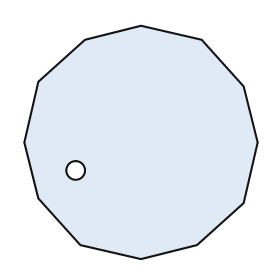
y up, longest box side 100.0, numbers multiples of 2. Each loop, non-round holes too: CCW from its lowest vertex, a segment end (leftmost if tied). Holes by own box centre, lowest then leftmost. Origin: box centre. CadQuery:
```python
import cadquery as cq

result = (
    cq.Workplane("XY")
    .moveTo(0.0, -50.0)
    .lineTo(24.0, -44.0)
    .lineTo(44.0, -26.0)
    .lineTo(50.0, 0.0)
    .lineTo(44.0, 24.0)
    .lineTo(26.0, 44.0)
    .lineTo(0.0, 50.0)
    .lineTo(-24.0, 44.0)
    .lineTo(-44.0, 26.0)
    .lineTo(-50.0, 0.0)
    .lineTo(-44.0, -24.0)
    .lineTo(-26.0, -44.0)
    .close()
    .moveTo(-28.0, -12.0)
    .circle(4.0)
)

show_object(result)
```